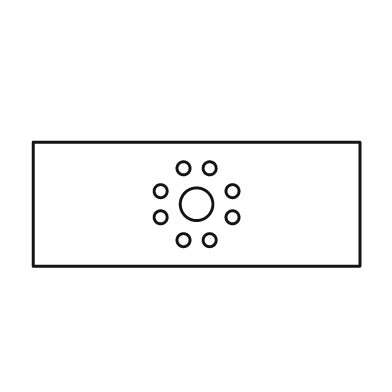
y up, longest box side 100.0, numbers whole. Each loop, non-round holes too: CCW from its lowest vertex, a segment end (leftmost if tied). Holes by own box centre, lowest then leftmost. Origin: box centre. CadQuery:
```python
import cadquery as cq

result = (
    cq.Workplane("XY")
    .moveTo(-50.0, -19.0)
    .lineTo(50.0, -19.0)
    .lineTo(50.0, 19.0)
    .lineTo(-50.0, 19.0)
    .close()
    .moveTo(-4.0, -11.0)
    .circle(2.0)
    .moveTo(4.0, -11.0)
    .circle(2.0)
    .moveTo(-11.0, -4.0)
    .circle(2.0)
    .moveTo(11.0, -4.0)
    .circle(2.0)
    .moveTo(0.0, 0.0)
    .circle(5.0)
    .moveTo(-11.0, 4.0)
    .circle(2.0)
    .moveTo(11.0, 4.0)
    .circle(2.0)
    .moveTo(-4.0, 11.0)
    .circle(2.0)
    .moveTo(4.0, 11.0)
    .circle(2.0)
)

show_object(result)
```